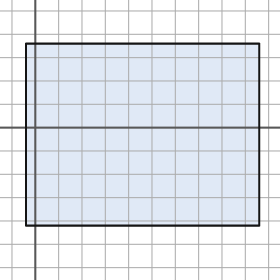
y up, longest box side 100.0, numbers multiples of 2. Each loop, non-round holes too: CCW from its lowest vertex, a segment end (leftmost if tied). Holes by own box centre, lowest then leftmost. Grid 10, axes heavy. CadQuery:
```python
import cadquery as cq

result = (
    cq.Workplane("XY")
    .moveTo(-4.0, -42.0)
    .lineTo(96.0, -42.0)
    .lineTo(96.0, 36.0)
    .lineTo(-4.0, 36.0)
    .close()
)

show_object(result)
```